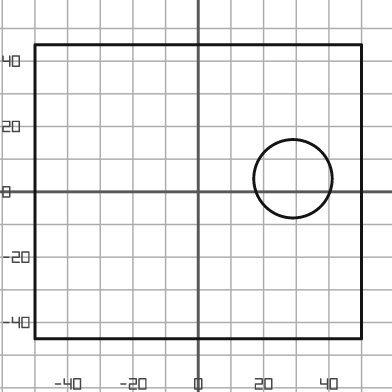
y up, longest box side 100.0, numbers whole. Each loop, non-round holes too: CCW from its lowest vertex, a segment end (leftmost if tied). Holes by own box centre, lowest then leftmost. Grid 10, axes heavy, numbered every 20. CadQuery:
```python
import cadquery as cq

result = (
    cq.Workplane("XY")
    .moveTo(-50.0, -45.0)
    .lineTo(50.0, -45.0)
    .lineTo(50.0, 45.0)
    .lineTo(-50.0, 45.0)
    .close()
    .moveTo(29.0, 4.0)
    .circle(12.0)
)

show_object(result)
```